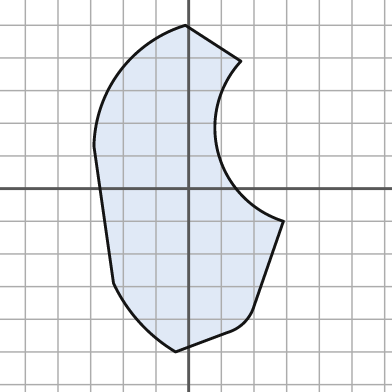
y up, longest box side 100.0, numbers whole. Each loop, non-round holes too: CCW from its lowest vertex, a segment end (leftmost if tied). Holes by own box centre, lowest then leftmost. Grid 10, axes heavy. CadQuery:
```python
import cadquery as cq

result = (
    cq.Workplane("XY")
    .moveTo(-4.0, -50.0)
    .lineTo(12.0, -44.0)
    .threePointArc((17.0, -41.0), (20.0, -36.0))
    .lineTo(29.0, -10.0)
    .threePointArc((9.0, 11.0), (16.0, 39.0))
    .lineTo(-1.0, 50.0)
    .threePointArc((-21.0, 36.0), (-29.0, 13.0))
    .lineTo(-23.0, -29.0)
    .threePointArc((-15.0, -41.0), (-4.0, -50.0))
    .close()
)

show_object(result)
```